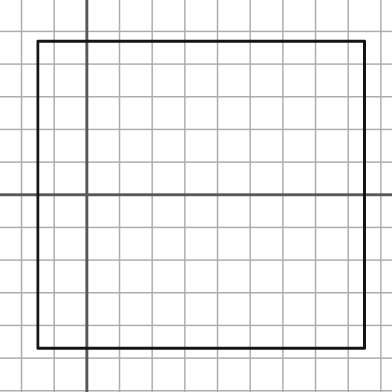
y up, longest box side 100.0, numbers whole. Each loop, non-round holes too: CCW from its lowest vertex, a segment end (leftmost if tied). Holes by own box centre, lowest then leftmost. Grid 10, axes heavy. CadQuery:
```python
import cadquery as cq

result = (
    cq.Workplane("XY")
    .moveTo(-15.0, -47.0)
    .lineTo(85.0, -47.0)
    .lineTo(85.0, 47.0)
    .lineTo(-15.0, 47.0)
    .close()
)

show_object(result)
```